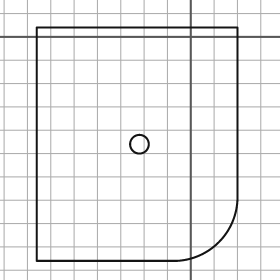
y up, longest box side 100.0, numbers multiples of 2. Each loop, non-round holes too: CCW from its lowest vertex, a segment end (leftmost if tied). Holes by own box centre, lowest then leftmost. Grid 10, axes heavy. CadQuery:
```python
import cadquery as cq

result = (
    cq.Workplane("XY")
    .moveTo(-66.0, -96.0)
    .lineTo(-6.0, -96.0)
    .threePointArc((12.0, -88.0), (20.0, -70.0))
    .lineTo(20.0, 4.0)
    .lineTo(-66.0, 4.0)
    .close()
    .moveTo(-22.0, -46.0)
    .circle(4.0)
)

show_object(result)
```